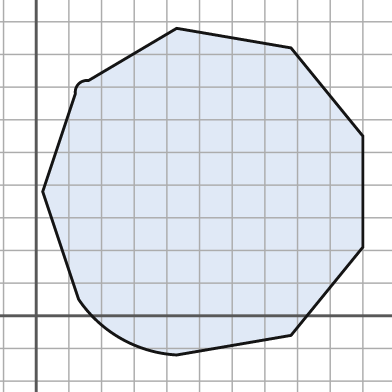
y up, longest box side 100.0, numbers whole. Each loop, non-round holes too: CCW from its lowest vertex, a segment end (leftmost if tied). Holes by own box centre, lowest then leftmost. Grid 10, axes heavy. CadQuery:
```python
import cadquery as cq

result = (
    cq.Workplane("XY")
    .moveTo(43.0, -12.0)
    .lineTo(78.0, -6.0)
    .lineTo(100.0, 21.0)
    .lineTo(100.0, 55.0)
    .lineTo(78.0, 82.0)
    .lineTo(43.0, 88.0)
    .lineTo(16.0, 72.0)
    .threePointArc((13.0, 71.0), (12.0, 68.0))
    .lineTo(2.0, 38.0)
    .lineTo(13.0, 5.0)
    .threePointArc((26.0, -7.0), (43.0, -12.0))
    .close()
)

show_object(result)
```